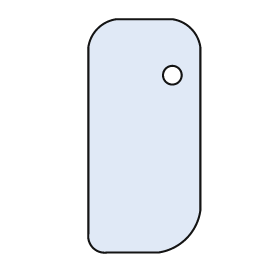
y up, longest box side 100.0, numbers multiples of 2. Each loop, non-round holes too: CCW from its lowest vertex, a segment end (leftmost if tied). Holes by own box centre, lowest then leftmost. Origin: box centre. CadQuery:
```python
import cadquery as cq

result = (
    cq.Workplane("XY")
    .moveTo(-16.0, -50.0)
    .lineTo(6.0, -50.0)
    .threePointArc((18.0, -44.0), (24.0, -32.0))
    .lineTo(24.0, 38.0)
    .threePointArc((20.0, 46.0), (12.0, 50.0))
    .lineTo(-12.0, 50.0)
    .threePointArc((-20.0, 46.0), (-24.0, 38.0))
    .lineTo(-24.0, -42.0)
    .threePointArc((-22.0, -48.0), (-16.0, -50.0))
    .close()
    .moveTo(12.0, 26.0)
    .circle(4.0)
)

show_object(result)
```